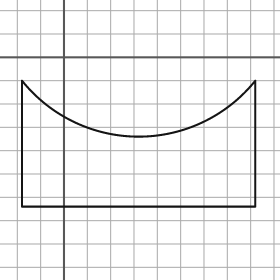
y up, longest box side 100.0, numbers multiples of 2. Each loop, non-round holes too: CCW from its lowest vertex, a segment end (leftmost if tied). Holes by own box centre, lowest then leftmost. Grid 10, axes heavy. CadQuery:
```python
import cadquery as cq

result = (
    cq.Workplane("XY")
    .moveTo(-18.0, -64.0)
    .lineTo(82.0, -64.0)
    .lineTo(82.0, -10.0)
    .threePointArc((32.0, -34.0), (-18.0, -10.0))
    .close()
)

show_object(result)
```